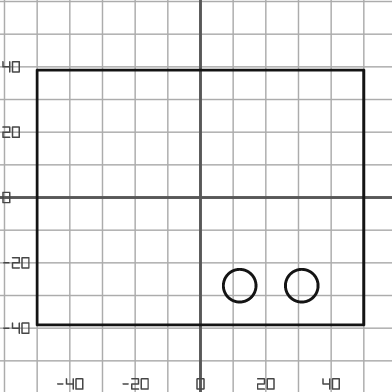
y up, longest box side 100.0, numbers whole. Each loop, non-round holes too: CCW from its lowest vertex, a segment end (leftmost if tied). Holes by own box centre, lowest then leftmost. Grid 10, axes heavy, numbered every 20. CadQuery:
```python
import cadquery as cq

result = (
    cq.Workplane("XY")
    .moveTo(-50.0, -39.0)
    .lineTo(50.0, -39.0)
    .lineTo(50.0, 39.0)
    .lineTo(-50.0, 39.0)
    .close()
    .moveTo(12.0, -27.0)
    .circle(5.0)
    .moveTo(31.0, -27.0)
    .circle(5.0)
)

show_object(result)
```